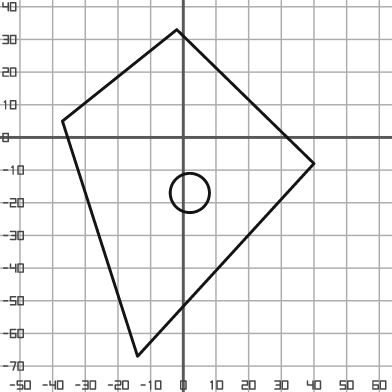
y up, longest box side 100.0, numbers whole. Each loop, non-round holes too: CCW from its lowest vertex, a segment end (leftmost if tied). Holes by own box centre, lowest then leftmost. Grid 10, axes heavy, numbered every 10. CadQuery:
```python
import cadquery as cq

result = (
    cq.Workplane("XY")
    .moveTo(-14.0, -67.0)
    .lineTo(40.0, -8.0)
    .lineTo(-2.0, 33.0)
    .lineTo(-37.0, 5.0)
    .close()
    .moveTo(2.0, -17.0)
    .circle(6.0)
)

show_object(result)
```